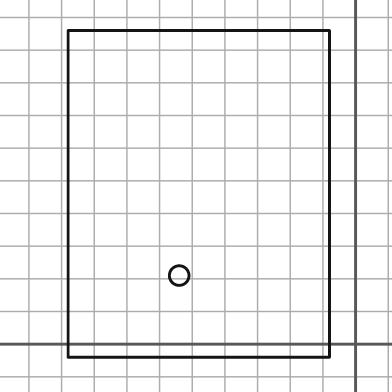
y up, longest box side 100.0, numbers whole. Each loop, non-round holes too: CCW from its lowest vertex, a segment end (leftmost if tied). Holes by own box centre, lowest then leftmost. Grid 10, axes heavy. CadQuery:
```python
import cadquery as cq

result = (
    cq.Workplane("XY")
    .moveTo(-88.0, -4.0)
    .lineTo(-8.0, -4.0)
    .lineTo(-8.0, 96.0)
    .lineTo(-88.0, 96.0)
    .close()
    .moveTo(-54.0, 21.0)
    .circle(3.0)
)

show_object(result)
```